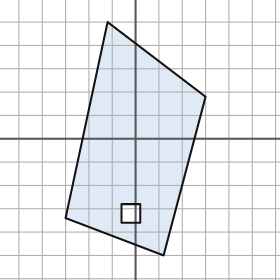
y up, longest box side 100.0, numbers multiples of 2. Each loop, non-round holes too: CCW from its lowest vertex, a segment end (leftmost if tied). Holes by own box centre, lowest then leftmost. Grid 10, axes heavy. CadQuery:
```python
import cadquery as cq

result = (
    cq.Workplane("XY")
    .moveTo(12.0, -50.0)
    .lineTo(30.0, 18.0)
    .lineTo(-12.0, 50.0)
    .lineTo(-30.0, -34.0)
    .close()
    .moveTo(-6.0, -36.0)
    .lineTo(2.0, -36.0)
    .lineTo(2.0, -28.0)
    .lineTo(-6.0, -28.0)
    .close()
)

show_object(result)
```